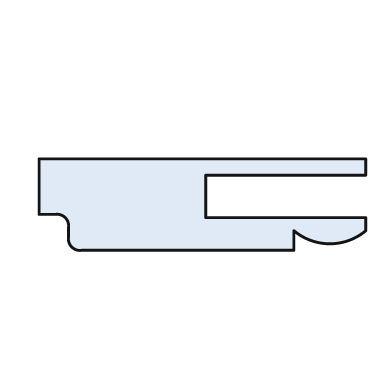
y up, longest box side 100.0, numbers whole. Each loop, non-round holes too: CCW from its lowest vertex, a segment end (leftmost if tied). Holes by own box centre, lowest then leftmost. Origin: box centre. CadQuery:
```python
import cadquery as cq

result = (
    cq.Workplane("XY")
    .moveTo(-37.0, -14.0)
    .lineTo(28.0, -14.0)
    .lineTo(28.0, -8.0)
    .threePointArc((39.0, -12.0), (50.0, -8.0))
    .lineTo(50.0, -4.0)
    .lineTo(1.0, -4.0)
    .lineTo(1.0, 9.0)
    .lineTo(50.0, 9.0)
    .lineTo(50.0, 14.0)
    .lineTo(-50.0, 14.0)
    .lineTo(-50.0, -3.0)
    .lineTo(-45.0, -3.0)
    .threePointArc((-42.0, -4.0), (-41.0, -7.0))
    .lineTo(-41.0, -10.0)
    .threePointArc((-40.0, -13.0), (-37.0, -14.0))
    .close()
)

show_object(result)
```